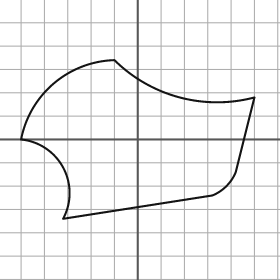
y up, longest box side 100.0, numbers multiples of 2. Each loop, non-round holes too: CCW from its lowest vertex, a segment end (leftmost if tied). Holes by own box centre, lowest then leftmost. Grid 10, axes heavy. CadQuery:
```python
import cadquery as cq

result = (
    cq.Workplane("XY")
    .moveTo(-32.0, -34.0)
    .lineTo(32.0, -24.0)
    .threePointArc((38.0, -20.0), (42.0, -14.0))
    .lineTo(50.0, 18.0)
    .threePointArc((18.0, 18.0), (-10.0, 34.0))
    .threePointArc((-36.0, 24.0), (-50.0, 0.0))
    .threePointArc((-32.0, -12.0), (-32.0, -34.0))
    .close()
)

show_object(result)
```